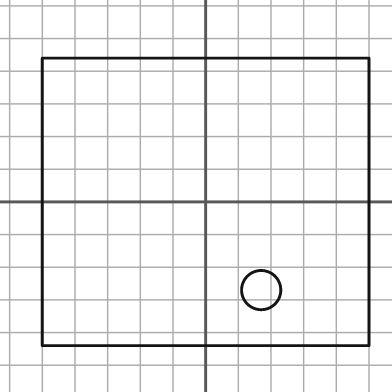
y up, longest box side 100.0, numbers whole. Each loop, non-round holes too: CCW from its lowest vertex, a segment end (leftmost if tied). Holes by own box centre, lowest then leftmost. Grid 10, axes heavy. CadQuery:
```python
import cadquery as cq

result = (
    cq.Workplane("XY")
    .moveTo(-50.0, -44.0)
    .lineTo(50.0, -44.0)
    .lineTo(50.0, 44.0)
    .lineTo(-50.0, 44.0)
    .close()
    .moveTo(17.0, -27.0)
    .circle(6.0)
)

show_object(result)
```